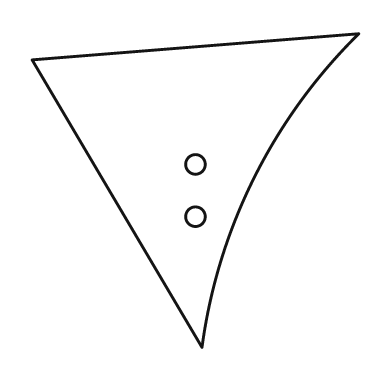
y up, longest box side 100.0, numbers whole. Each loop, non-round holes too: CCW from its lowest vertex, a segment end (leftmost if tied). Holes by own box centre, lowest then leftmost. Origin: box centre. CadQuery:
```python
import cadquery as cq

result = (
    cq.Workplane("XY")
    .moveTo(2.0, -48.0)
    .threePointArc((18.0, 4.0), (50.0, 48.0))
    .lineTo(-50.0, 40.0)
    .close()
    .moveTo(0.0, -8.0)
    .circle(3.0)
    .moveTo(0.0, 8.0)
    .circle(3.0)
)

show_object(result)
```